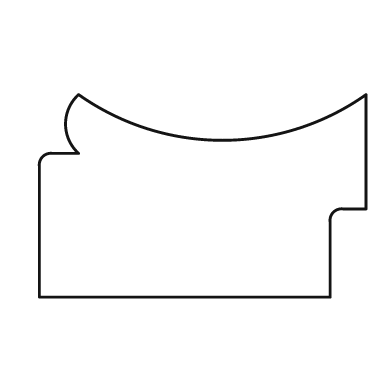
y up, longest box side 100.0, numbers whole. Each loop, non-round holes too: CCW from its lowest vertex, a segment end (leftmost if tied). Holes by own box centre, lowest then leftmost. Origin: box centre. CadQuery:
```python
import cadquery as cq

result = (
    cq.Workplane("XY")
    .moveTo(-50.0, -31.0)
    .lineTo(39.0, -31.0)
    .lineTo(39.0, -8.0)
    .threePointArc((40.0, -5.0), (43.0, -4.0))
    .lineTo(50.0, -4.0)
    .lineTo(50.0, 31.0)
    .threePointArc((6.0, 17.0), (-38.0, 31.0))
    .threePointArc((-42.0, 22.0), (-38.0, 13.0))
    .lineTo(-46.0, 13.0)
    .threePointArc((-49.0, 12.0), (-50.0, 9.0))
    .close()
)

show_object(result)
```